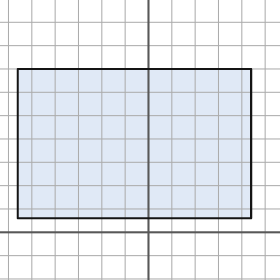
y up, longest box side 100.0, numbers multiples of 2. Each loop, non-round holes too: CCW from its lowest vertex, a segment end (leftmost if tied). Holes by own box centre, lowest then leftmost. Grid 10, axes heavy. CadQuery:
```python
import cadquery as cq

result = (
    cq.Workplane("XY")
    .moveTo(-56.0, 6.0)
    .lineTo(44.0, 6.0)
    .lineTo(44.0, 70.0)
    .lineTo(-56.0, 70.0)
    .close()
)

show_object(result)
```